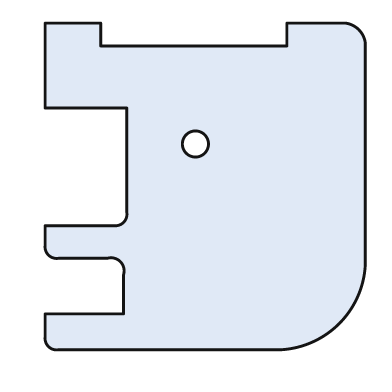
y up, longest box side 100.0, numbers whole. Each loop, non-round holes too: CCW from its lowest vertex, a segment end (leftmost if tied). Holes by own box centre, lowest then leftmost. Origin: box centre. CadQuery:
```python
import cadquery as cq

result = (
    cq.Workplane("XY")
    .moveTo(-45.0, -50.0)
    .lineTo(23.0, -50.0)
    .threePointArc((41.0, -42.0), (49.0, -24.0))
    .lineTo(49.0, 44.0)
    .threePointArc((47.0, 48.0), (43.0, 50.0))
    .lineTo(25.0, 50.0)
    .lineTo(25.0, 43.0)
    .lineTo(-32.0, 43.0)
    .lineTo(-32.0, 50.0)
    .lineTo(-49.0, 50.0)
    .lineTo(-49.0, 24.0)
    .lineTo(-24.0, 24.0)
    .lineTo(-24.0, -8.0)
    .threePointArc((-25.0, -11.0), (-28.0, -12.0))
    .lineTo(-49.0, -12.0)
    .lineTo(-49.0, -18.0)
    .threePointArc((-48.0, -21.0), (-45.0, -22.0))
    .lineTo(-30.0, -22.0)
    .threePointArc((-26.0, -23.0), (-25.0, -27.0))
    .lineTo(-25.0, -39.0)
    .lineTo(-49.0, -39.0)
    .lineTo(-49.0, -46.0)
    .threePointArc((-48.0, -49.0), (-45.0, -50.0))
    .close()
    .moveTo(-3.0, 13.0)
    .circle(4.0)
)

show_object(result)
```